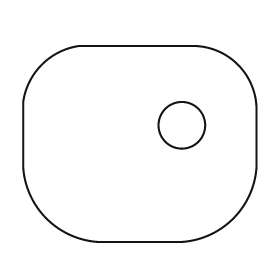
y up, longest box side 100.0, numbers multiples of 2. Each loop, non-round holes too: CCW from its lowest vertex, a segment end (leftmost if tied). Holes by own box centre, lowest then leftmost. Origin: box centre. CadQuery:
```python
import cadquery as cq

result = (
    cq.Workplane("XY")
    .moveTo(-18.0, -42.0)
    .lineTo(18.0, -42.0)
    .threePointArc((40.0, -32.0), (50.0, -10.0))
    .lineTo(50.0, 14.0)
    .threePointArc((42.0, 34.0), (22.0, 42.0))
    .lineTo(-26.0, 42.0)
    .threePointArc((-42.0, 34.0), (-50.0, 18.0))
    .lineTo(-50.0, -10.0)
    .threePointArc((-40.0, -32.0), (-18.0, -42.0))
    .close()
    .moveTo(18.0, 8.0)
    .circle(10.0)
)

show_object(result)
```